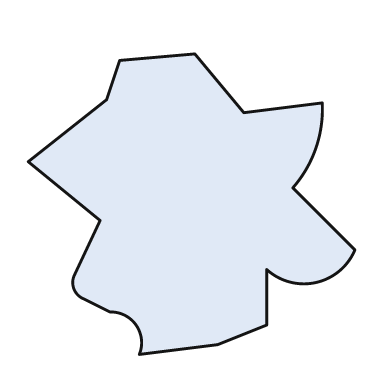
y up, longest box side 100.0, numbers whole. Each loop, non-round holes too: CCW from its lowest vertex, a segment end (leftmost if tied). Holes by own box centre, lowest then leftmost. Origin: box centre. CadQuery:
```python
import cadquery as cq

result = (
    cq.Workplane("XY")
    .moveTo(-16.0, -46.0)
    .lineTo(8.0, -43.0)
    .lineTo(23.0, -37.0)
    .lineTo(23.0, -20.0)
    .threePointArc((38.0, -24.0), (50.0, -14.0))
    .lineTo(31.0, 5.0)
    .threePointArc((38.0, 17.0), (40.0, 31.0))
    .lineTo(16.0, 28.0)
    .lineTo(1.0, 46.0)
    .lineTo(-22.0, 44.0)
    .lineTo(-26.0, 32.0)
    .lineTo(-50.0, 13.0)
    .lineTo(-28.0, -5.0)
    .lineTo(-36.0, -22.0)
    .threePointArc((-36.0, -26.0), (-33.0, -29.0))
    .lineTo(-25.0, -33.0)
    .threePointArc((-17.0, -37.0), (-16.0, -46.0))
    .close()
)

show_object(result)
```